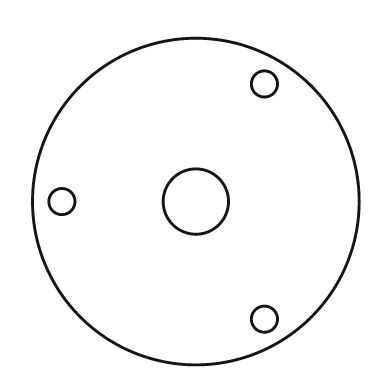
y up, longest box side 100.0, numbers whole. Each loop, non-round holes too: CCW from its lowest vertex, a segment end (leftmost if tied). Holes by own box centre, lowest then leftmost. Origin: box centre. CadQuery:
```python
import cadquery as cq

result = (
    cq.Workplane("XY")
    .moveTo(0.0, 0.0)
    .circle(50.0)
    .moveTo(21.0, -36.0)
    .circle(4.0)
    .moveTo(-41.0, 0.0)
    .circle(4.0)
    .moveTo(0.0, 0.0)
    .circle(10.0)
    .moveTo(21.0, 36.0)
    .circle(4.0)
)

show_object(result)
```